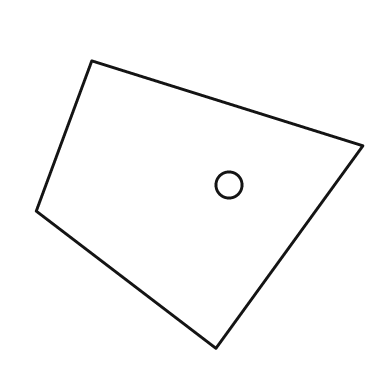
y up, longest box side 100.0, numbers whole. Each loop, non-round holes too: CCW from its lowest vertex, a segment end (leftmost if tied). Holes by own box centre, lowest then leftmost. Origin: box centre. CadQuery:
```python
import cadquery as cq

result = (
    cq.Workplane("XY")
    .moveTo(5.0, -44.0)
    .lineTo(50.0, 18.0)
    .lineTo(-33.0, 44.0)
    .lineTo(-50.0, -2.0)
    .close()
    .moveTo(9.0, 6.0)
    .circle(4.0)
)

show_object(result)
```